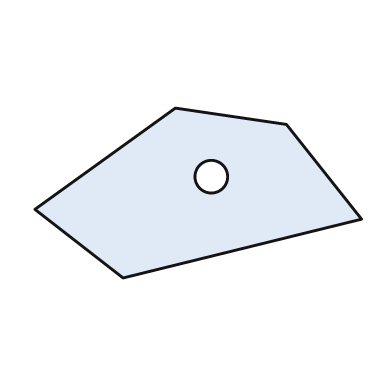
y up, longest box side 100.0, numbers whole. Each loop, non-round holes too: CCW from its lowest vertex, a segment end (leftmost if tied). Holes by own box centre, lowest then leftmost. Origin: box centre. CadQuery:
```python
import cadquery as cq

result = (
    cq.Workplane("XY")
    .moveTo(-23.0, -26.0)
    .lineTo(50.0, -8.0)
    .lineTo(27.0, 21.0)
    .lineTo(-7.0, 26.0)
    .lineTo(-50.0, -5.0)
    .close()
    .moveTo(4.0, 5.0)
    .circle(5.0)
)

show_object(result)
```